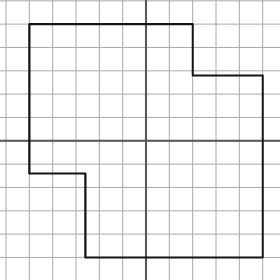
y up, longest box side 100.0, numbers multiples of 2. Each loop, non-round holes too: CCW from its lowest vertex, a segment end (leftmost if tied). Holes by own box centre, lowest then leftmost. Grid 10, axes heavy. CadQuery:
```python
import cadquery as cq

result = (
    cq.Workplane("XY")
    .moveTo(-26.0, -50.0)
    .lineTo(50.0, -50.0)
    .lineTo(50.0, 28.0)
    .lineTo(20.0, 28.0)
    .lineTo(20.0, 50.0)
    .lineTo(-50.0, 50.0)
    .lineTo(-50.0, -14.0)
    .lineTo(-26.0, -14.0)
    .close()
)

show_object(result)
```